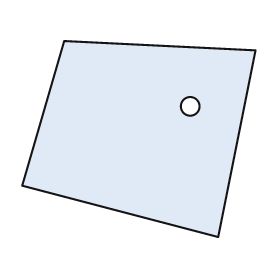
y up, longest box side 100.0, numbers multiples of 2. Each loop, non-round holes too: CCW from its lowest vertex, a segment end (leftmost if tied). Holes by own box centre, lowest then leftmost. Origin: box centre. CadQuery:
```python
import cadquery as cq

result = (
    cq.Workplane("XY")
    .moveTo(34.0, -42.0)
    .lineTo(50.0, 38.0)
    .lineTo(-32.0, 42.0)
    .lineTo(-50.0, -20.0)
    .close()
    .moveTo(22.0, 14.0)
    .circle(4.0)
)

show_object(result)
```